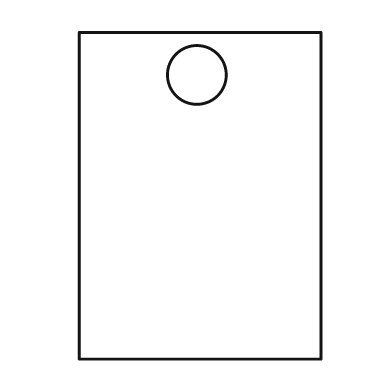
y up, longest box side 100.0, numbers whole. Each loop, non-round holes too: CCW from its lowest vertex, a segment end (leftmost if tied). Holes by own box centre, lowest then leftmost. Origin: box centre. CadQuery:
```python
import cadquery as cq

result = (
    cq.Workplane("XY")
    .moveTo(-37.0, -50.0)
    .lineTo(37.0, -50.0)
    .lineTo(37.0, 50.0)
    .lineTo(-37.0, 50.0)
    .close()
    .moveTo(-1.0, 37.0)
    .circle(9.0)
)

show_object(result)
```